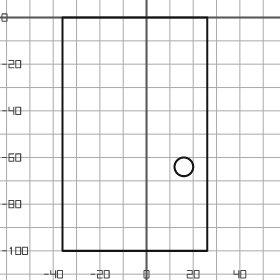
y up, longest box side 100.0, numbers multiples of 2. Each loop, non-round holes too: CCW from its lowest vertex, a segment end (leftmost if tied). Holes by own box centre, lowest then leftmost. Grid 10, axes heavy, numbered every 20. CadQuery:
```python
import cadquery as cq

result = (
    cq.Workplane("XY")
    .moveTo(-36.0, -100.0)
    .lineTo(26.0, -100.0)
    .lineTo(26.0, 0.0)
    .lineTo(-36.0, 0.0)
    .close()
    .moveTo(16.0, -64.0)
    .circle(4.0)
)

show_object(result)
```